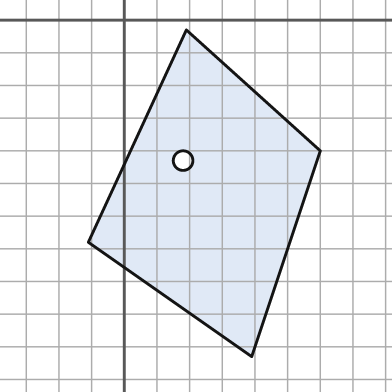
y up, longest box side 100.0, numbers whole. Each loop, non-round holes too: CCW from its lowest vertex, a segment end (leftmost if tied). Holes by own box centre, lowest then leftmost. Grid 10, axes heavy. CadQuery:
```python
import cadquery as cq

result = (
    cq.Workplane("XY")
    .moveTo(39.0, -103.0)
    .lineTo(60.0, -40.0)
    .lineTo(19.0, -3.0)
    .lineTo(-11.0, -68.0)
    .close()
    .moveTo(18.0, -43.0)
    .circle(3.0)
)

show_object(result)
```